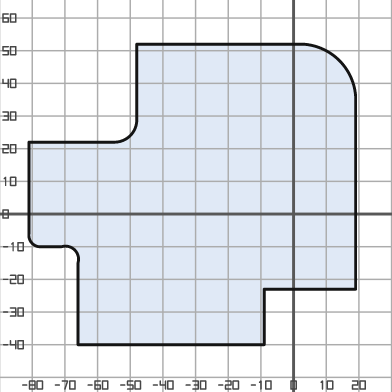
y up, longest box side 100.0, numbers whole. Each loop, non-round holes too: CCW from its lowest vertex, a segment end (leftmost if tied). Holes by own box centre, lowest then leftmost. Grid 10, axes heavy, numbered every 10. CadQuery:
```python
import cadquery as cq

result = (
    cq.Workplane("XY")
    .moveTo(-66.0, -40.0)
    .lineTo(-9.0, -40.0)
    .lineTo(-9.0, -23.0)
    .lineTo(19.0, -23.0)
    .lineTo(19.0, 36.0)
    .threePointArc((14.0, 47.0), (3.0, 52.0))
    .lineTo(-48.0, 52.0)
    .lineTo(-48.0, 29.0)
    .threePointArc((-50.0, 24.0), (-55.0, 22.0))
    .lineTo(-81.0, 22.0)
    .lineTo(-81.0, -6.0)
    .threePointArc((-80.0, -9.0), (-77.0, -10.0))
    .lineTo(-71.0, -10.0)
    .threePointArc((-67.0, -11.0), (-66.0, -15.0))
    .close()
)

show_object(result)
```